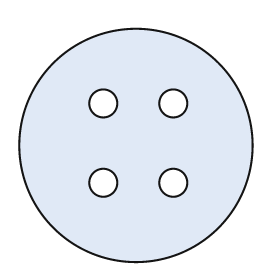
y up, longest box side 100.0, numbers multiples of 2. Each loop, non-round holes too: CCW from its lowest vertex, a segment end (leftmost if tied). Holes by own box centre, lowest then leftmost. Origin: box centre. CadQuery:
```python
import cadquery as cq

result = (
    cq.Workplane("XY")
    .moveTo(0.0, 0.0)
    .circle(50.0)
    .moveTo(-14.0, -16.0)
    .circle(6.0)
    .moveTo(16.0, -16.0)
    .circle(6.0)
    .moveTo(-14.0, 18.0)
    .circle(6.0)
    .moveTo(16.0, 18.0)
    .circle(6.0)
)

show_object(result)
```